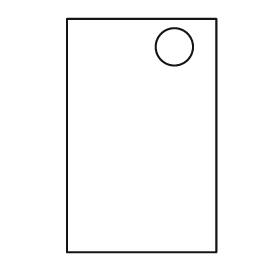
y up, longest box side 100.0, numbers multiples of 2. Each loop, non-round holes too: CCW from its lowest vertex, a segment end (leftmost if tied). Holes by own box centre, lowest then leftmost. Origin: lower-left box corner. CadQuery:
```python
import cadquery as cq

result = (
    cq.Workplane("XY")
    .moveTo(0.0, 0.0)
    .lineTo(64.0, 0.0)
    .lineTo(64.0, 100.0)
    .lineTo(0.0, 100.0)
    .close()
    .moveTo(46.0, 88.0)
    .circle(8.0)
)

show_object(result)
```